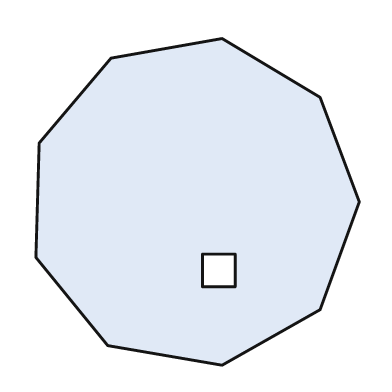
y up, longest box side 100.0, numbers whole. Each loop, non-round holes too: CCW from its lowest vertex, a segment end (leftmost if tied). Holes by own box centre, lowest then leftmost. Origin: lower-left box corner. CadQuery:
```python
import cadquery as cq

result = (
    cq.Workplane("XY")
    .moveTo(57.0, 0.0)
    .lineTo(87.0, 17.0)
    .lineTo(99.0, 50.0)
    .lineTo(87.0, 82.0)
    .lineTo(57.0, 100.0)
    .lineTo(23.0, 94.0)
    .lineTo(1.0, 68.0)
    .lineTo(0.0, 33.0)
    .lineTo(22.0, 6.0)
    .close()
    .moveTo(51.0, 24.0)
    .lineTo(61.0, 24.0)
    .lineTo(61.0, 34.0)
    .lineTo(51.0, 34.0)
    .close()
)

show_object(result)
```